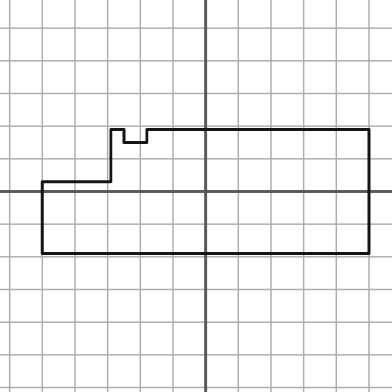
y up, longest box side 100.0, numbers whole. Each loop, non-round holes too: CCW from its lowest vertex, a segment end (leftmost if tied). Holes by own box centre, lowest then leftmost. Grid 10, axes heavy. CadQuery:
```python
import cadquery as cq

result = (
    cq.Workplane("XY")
    .moveTo(-50.0, -19.0)
    .lineTo(50.0, -19.0)
    .lineTo(50.0, 19.0)
    .lineTo(-18.0, 19.0)
    .lineTo(-18.0, 15.0)
    .lineTo(-25.0, 15.0)
    .lineTo(-25.0, 19.0)
    .lineTo(-29.0, 19.0)
    .lineTo(-29.0, 3.0)
    .lineTo(-50.0, 3.0)
    .close()
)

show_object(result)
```